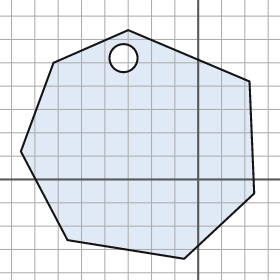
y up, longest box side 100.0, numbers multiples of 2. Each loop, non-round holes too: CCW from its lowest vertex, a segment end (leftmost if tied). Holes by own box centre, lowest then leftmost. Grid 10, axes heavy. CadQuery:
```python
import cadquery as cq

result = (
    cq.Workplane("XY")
    .moveTo(-6.0, -34.0)
    .lineTo(24.0, -6.0)
    .lineTo(22.0, 42.0)
    .lineTo(-30.0, 64.0)
    .lineTo(-62.0, 50.0)
    .lineTo(-76.0, 12.0)
    .lineTo(-56.0, -26.0)
    .close()
    .moveTo(-32.0, 52.0)
    .circle(6.0)
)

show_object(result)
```